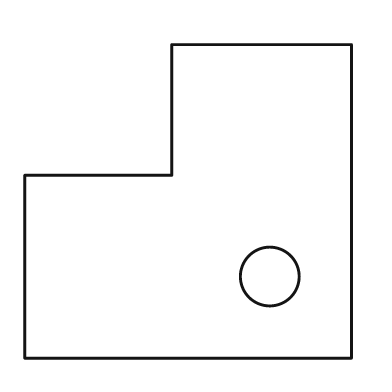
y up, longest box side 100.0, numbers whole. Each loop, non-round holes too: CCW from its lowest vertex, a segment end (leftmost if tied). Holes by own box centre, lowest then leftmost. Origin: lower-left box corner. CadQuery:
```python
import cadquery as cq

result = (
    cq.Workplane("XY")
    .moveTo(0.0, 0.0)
    .lineTo(100.0, 0.0)
    .lineTo(100.0, 96.0)
    .lineTo(45.0, 96.0)
    .lineTo(45.0, 56.0)
    .lineTo(0.0, 56.0)
    .close()
    .moveTo(75.0, 25.0)
    .circle(9.0)
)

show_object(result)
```